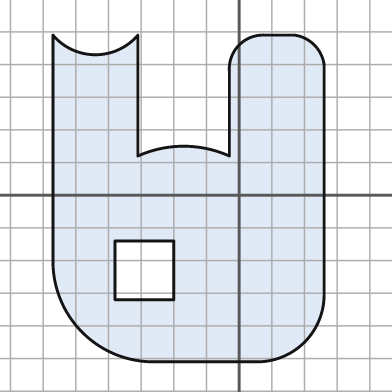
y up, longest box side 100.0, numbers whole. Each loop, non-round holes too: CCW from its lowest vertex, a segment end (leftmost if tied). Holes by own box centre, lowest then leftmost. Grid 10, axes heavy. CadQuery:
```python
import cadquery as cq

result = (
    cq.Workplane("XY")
    .moveTo(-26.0, -51.0)
    .lineTo(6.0, -51.0)
    .threePointArc((20.0, -45.0), (26.0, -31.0))
    .lineTo(26.0, 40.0)
    .threePointArc((23.0, 46.0), (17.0, 49.0))
    .lineTo(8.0, 49.0)
    .threePointArc((0.0, 46.0), (-3.0, 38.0))
    .lineTo(-3.0, 12.0)
    .threePointArc((-17.0, 15.0), (-31.0, 12.0))
    .lineTo(-31.0, 49.0)
    .threePointArc((-44.0, 43.0), (-57.0, 49.0))
    .lineTo(-57.0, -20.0)
    .threePointArc((-48.0, -42.0), (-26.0, -51.0))
    .close()
    .moveTo(-38.0, -32.0)
    .lineTo(-20.0, -32.0)
    .lineTo(-20.0, -14.0)
    .lineTo(-38.0, -14.0)
    .close()
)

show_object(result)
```